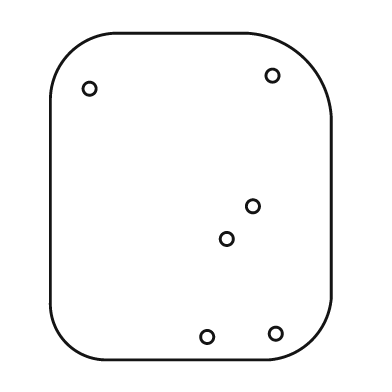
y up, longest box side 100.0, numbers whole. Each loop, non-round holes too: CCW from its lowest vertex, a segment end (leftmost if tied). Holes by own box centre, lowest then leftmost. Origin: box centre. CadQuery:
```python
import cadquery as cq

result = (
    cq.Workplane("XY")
    .moveTo(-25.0, -50.0)
    .lineTo(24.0, -50.0)
    .threePointArc((37.0, -44.0), (43.0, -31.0))
    .lineTo(43.0, 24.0)
    .threePointArc((35.0, 42.0), (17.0, 50.0))
    .lineTo(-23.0, 50.0)
    .threePointArc((-37.0, 44.0), (-43.0, 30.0))
    .lineTo(-43.0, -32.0)
    .threePointArc((-38.0, -45.0), (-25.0, -50.0))
    .close()
    .moveTo(5.0, -43.0)
    .circle(2.0)
    .moveTo(26.0, -42.0)
    .circle(2.0)
    .moveTo(11.0, -13.0)
    .circle(2.0)
    .moveTo(19.0, -3.0)
    .circle(2.0)
    .moveTo(-31.0, 33.0)
    .circle(2.0)
    .moveTo(25.0, 37.0)
    .circle(2.0)
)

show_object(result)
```